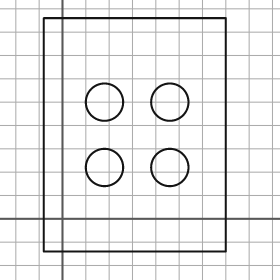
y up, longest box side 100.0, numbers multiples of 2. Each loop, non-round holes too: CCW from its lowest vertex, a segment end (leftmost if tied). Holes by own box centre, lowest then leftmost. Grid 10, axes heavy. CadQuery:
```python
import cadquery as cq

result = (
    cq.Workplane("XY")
    .moveTo(-8.0, -14.0)
    .lineTo(70.0, -14.0)
    .lineTo(70.0, 86.0)
    .lineTo(-8.0, 86.0)
    .close()
    .moveTo(18.0, 22.0)
    .circle(8.0)
    .moveTo(46.0, 22.0)
    .circle(8.0)
    .moveTo(18.0, 50.0)
    .circle(8.0)
    .moveTo(46.0, 50.0)
    .circle(8.0)
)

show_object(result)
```